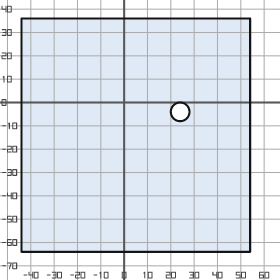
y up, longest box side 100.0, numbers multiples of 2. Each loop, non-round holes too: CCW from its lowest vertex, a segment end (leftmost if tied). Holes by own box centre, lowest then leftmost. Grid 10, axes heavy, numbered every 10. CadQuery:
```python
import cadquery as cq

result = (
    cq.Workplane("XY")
    .moveTo(-44.0, -64.0)
    .lineTo(54.0, -64.0)
    .lineTo(54.0, 36.0)
    .lineTo(-44.0, 36.0)
    .close()
    .moveTo(24.0, -4.0)
    .circle(4.0)
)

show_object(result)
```